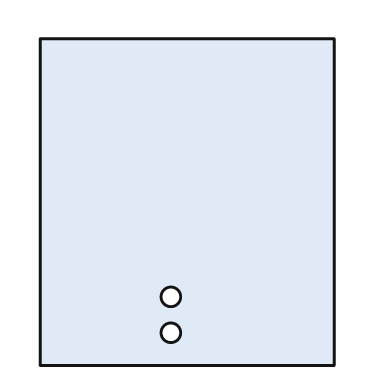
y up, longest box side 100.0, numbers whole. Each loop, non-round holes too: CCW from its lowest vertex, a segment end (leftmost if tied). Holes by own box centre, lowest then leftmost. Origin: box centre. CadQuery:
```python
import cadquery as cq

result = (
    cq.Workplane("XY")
    .moveTo(-45.0, -50.0)
    .lineTo(45.0, -50.0)
    .lineTo(45.0, 50.0)
    .lineTo(-45.0, 50.0)
    .close()
    .moveTo(-5.0, -40.0)
    .circle(3.0)
    .moveTo(-5.0, -29.0)
    .circle(3.0)
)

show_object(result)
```